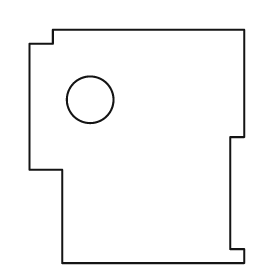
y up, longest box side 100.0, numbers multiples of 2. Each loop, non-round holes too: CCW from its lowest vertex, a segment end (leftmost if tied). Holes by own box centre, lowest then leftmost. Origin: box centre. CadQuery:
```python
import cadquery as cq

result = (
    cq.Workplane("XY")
    .moveTo(-32.0, -50.0)
    .lineTo(46.0, -50.0)
    .lineTo(46.0, -44.0)
    .lineTo(40.0, -44.0)
    .lineTo(40.0, 4.0)
    .lineTo(46.0, 4.0)
    .lineTo(46.0, 50.0)
    .lineTo(-36.0, 50.0)
    .lineTo(-36.0, 44.0)
    .lineTo(-46.0, 44.0)
    .lineTo(-46.0, -10.0)
    .lineTo(-32.0, -10.0)
    .close()
    .moveTo(-20.0, 20.0)
    .circle(10.0)
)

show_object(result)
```